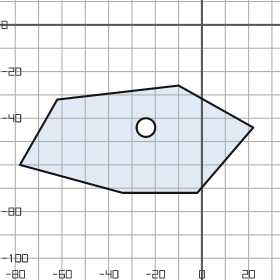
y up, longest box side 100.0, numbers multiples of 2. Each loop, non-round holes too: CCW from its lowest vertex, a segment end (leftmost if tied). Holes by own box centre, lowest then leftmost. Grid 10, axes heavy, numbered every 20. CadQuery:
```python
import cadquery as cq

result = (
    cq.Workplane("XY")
    .moveTo(-34.0, -72.0)
    .lineTo(-2.0, -72.0)
    .lineTo(22.0, -44.0)
    .lineTo(-10.0, -26.0)
    .lineTo(-62.0, -32.0)
    .lineTo(-78.0, -60.0)
    .close()
    .moveTo(-24.0, -44.0)
    .circle(4.0)
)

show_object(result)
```